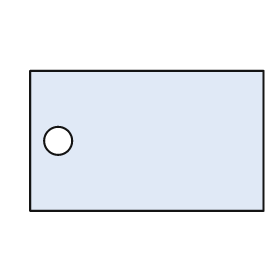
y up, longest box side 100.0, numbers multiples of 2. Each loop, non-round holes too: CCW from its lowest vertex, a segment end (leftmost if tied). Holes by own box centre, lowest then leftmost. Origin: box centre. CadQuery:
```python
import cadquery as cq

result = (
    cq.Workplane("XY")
    .moveTo(-50.0, -30.0)
    .lineTo(50.0, -30.0)
    .lineTo(50.0, 30.0)
    .lineTo(-50.0, 30.0)
    .close()
    .moveTo(-38.0, 0.0)
    .circle(6.0)
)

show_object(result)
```